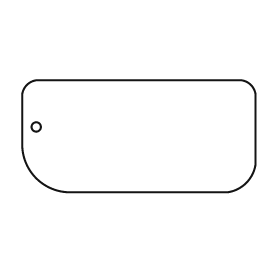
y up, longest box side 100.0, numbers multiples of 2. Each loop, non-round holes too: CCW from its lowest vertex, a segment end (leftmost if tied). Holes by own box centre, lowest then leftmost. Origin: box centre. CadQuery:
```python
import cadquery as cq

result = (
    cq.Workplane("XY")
    .moveTo(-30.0, -24.0)
    .lineTo(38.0, -24.0)
    .threePointArc((46.0, -20.0), (50.0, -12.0))
    .lineTo(50.0, 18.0)
    .threePointArc((48.0, 22.0), (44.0, 24.0))
    .lineTo(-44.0, 24.0)
    .threePointArc((-48.0, 22.0), (-50.0, 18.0))
    .lineTo(-50.0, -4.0)
    .threePointArc((-44.0, -18.0), (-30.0, -24.0))
    .close()
    .moveTo(-44.0, 4.0)
    .circle(2.0)
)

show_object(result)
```